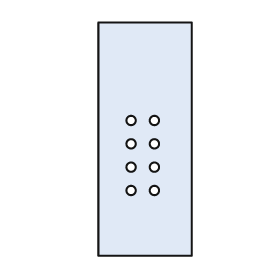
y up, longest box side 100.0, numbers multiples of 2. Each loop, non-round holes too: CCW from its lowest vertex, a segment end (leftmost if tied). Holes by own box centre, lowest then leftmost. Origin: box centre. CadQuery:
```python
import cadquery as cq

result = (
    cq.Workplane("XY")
    .moveTo(-20.0, -50.0)
    .lineTo(20.0, -50.0)
    .lineTo(20.0, 50.0)
    .lineTo(-20.0, 50.0)
    .close()
    .moveTo(-6.0, -22.0)
    .circle(2.0)
    .moveTo(4.0, -22.0)
    .circle(2.0)
    .moveTo(-6.0, -12.0)
    .circle(2.0)
    .moveTo(4.0, -12.0)
    .circle(2.0)
    .moveTo(-6.0, -2.0)
    .circle(2.0)
    .moveTo(4.0, -2.0)
    .circle(2.0)
    .moveTo(-6.0, 8.0)
    .circle(2.0)
    .moveTo(4.0, 8.0)
    .circle(2.0)
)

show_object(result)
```